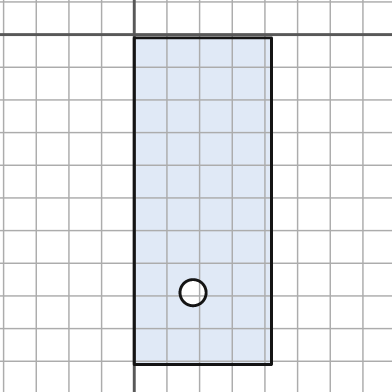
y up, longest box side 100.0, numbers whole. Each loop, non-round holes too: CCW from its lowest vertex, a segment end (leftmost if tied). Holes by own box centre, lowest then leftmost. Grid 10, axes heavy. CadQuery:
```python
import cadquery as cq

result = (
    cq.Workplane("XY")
    .moveTo(0.0, -101.0)
    .lineTo(42.0, -101.0)
    .lineTo(42.0, -1.0)
    .lineTo(0.0, -1.0)
    .close()
    .moveTo(18.0, -79.0)
    .circle(4.0)
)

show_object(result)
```